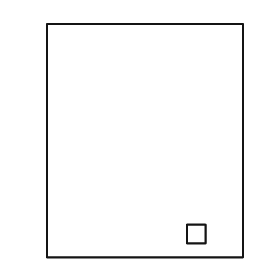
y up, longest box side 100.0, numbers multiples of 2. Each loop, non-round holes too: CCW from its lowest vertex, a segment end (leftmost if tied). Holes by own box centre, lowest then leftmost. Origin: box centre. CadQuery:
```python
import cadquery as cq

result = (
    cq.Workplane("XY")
    .moveTo(-42.0, -50.0)
    .lineTo(42.0, -50.0)
    .lineTo(42.0, 50.0)
    .lineTo(-42.0, 50.0)
    .close()
    .moveTo(18.0, -44.0)
    .lineTo(26.0, -44.0)
    .lineTo(26.0, -36.0)
    .lineTo(18.0, -36.0)
    .close()
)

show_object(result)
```